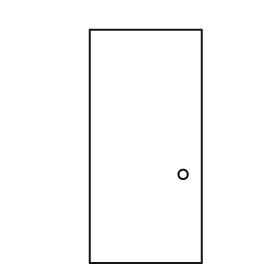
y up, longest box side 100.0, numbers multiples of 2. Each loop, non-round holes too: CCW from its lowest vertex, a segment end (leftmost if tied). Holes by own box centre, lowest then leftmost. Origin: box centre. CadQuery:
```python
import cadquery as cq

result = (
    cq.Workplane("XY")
    .moveTo(-24.0, -50.0)
    .lineTo(24.0, -50.0)
    .lineTo(24.0, 50.0)
    .lineTo(-24.0, 50.0)
    .close()
    .moveTo(16.0, -12.0)
    .circle(2.0)
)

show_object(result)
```